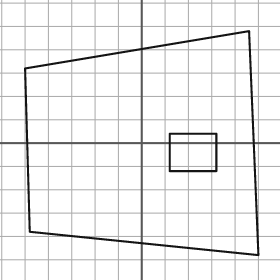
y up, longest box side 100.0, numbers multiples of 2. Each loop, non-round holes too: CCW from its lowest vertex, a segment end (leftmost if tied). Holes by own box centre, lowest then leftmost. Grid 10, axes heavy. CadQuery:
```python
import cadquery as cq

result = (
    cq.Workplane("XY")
    .moveTo(50.0, -48.0)
    .lineTo(46.0, 48.0)
    .lineTo(-50.0, 32.0)
    .lineTo(-48.0, -38.0)
    .close()
    .moveTo(12.0, -12.0)
    .lineTo(32.0, -12.0)
    .lineTo(32.0, 4.0)
    .lineTo(12.0, 4.0)
    .close()
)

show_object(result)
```